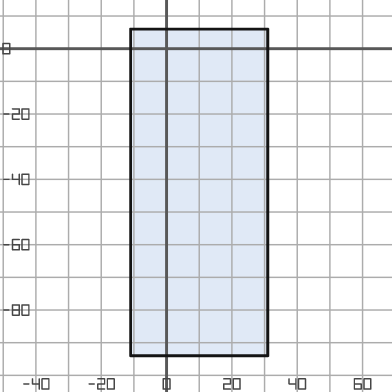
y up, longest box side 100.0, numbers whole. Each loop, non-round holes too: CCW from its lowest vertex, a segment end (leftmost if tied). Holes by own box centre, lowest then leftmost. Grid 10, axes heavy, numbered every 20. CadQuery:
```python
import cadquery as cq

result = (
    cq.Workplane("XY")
    .moveTo(-11.0, -94.0)
    .lineTo(31.0, -94.0)
    .lineTo(31.0, 6.0)
    .lineTo(-11.0, 6.0)
    .close()
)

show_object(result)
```